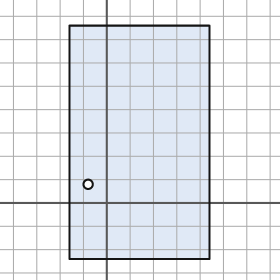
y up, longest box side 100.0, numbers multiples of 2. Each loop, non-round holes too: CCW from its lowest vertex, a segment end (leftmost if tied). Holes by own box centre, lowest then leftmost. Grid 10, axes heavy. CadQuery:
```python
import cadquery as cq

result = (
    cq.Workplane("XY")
    .moveTo(-16.0, -24.0)
    .lineTo(44.0, -24.0)
    .lineTo(44.0, 76.0)
    .lineTo(-16.0, 76.0)
    .close()
    .moveTo(-8.0, 8.0)
    .circle(2.0)
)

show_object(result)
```